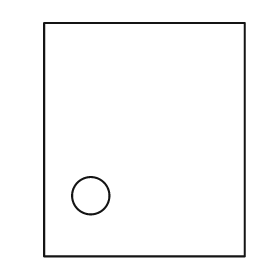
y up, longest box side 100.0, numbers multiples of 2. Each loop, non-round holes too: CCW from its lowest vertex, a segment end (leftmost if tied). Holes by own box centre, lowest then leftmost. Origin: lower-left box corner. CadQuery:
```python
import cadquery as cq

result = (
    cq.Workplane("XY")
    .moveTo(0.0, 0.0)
    .lineTo(86.0, 0.0)
    .lineTo(86.0, 100.0)
    .lineTo(0.0, 100.0)
    .close()
    .moveTo(20.0, 26.0)
    .circle(8.0)
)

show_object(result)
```